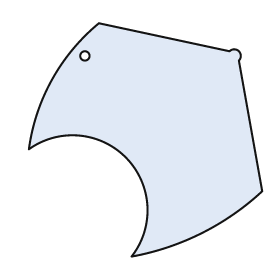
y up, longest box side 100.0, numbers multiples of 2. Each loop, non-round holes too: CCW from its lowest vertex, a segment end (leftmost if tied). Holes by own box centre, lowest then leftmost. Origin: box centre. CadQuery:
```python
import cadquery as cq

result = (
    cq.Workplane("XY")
    .moveTo(-6.0, -50.0)
    .threePointArc((24.0, -40.0), (50.0, -22.0))
    .lineTo(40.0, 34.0)
    .threePointArc((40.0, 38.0), (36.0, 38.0))
    .lineTo(-20.0, 50.0)
    .threePointArc((-40.0, 26.0), (-50.0, -4.0))
    .threePointArc((-8.0, -8.0), (-6.0, -50.0))
    .close()
    .moveTo(-26.0, 36.0)
    .circle(2.0)
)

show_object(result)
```